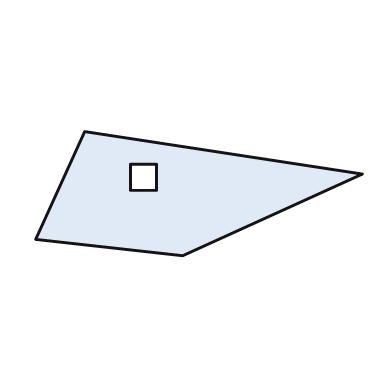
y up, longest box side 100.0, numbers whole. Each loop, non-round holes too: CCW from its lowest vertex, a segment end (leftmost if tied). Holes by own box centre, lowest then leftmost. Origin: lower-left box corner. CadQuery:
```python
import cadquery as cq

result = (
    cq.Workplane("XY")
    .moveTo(45.0, 0.0)
    .lineTo(100.0, 25.0)
    .lineTo(15.0, 38.0)
    .lineTo(0.0, 5.0)
    .close()
    .moveTo(29.0, 20.0)
    .lineTo(37.0, 20.0)
    .lineTo(37.0, 28.0)
    .lineTo(29.0, 28.0)
    .close()
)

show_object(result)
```